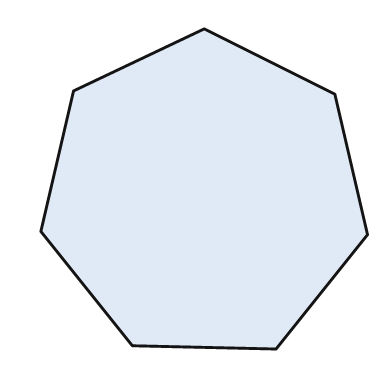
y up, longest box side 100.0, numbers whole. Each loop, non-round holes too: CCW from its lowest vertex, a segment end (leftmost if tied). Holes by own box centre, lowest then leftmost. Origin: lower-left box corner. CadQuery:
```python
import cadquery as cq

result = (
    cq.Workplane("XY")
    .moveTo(72.0, 0.0)
    .lineTo(100.0, 35.0)
    .lineTo(90.0, 78.0)
    .lineTo(50.0, 98.0)
    .lineTo(10.0, 79.0)
    .lineTo(0.0, 36.0)
    .lineTo(28.0, 1.0)
    .close()
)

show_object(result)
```